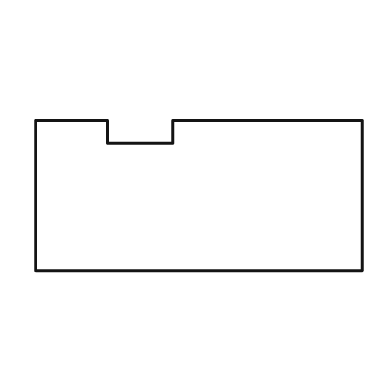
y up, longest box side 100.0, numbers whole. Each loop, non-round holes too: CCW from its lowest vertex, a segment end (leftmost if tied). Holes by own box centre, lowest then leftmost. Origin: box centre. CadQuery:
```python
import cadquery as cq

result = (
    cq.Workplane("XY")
    .moveTo(-50.0, -23.0)
    .lineTo(50.0, -23.0)
    .lineTo(50.0, 23.0)
    .lineTo(-8.0, 23.0)
    .lineTo(-8.0, 16.0)
    .lineTo(-28.0, 16.0)
    .lineTo(-28.0, 23.0)
    .lineTo(-50.0, 23.0)
    .close()
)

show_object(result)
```